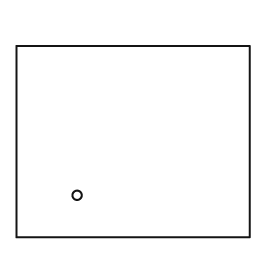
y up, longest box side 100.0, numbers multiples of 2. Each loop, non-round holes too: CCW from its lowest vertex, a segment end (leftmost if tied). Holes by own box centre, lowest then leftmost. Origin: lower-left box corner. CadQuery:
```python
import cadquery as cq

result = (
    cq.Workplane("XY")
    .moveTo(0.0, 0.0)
    .lineTo(100.0, 0.0)
    .lineTo(100.0, 82.0)
    .lineTo(0.0, 82.0)
    .close()
    .moveTo(26.0, 18.0)
    .circle(2.0)
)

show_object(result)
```